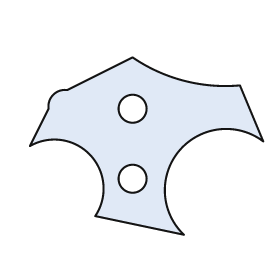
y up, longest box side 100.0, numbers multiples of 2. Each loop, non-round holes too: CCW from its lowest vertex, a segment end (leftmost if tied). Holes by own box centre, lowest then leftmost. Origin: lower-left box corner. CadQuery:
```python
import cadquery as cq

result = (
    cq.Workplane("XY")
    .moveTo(66.0, 0.0)
    .threePointArc((64.0, 36.0), (100.0, 40.0))
    .lineTo(90.0, 64.0)
    .threePointArc((66.0, 66.0), (44.0, 76.0))
    .lineTo(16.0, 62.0)
    .threePointArc((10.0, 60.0), (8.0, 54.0))
    .lineTo(0.0, 38.0)
    .threePointArc((26.0, 34.0), (28.0, 8.0))
    .close()
    .moveTo(44.0, 24.0)
    .circle(6.0)
    .moveTo(44.0, 54.0)
    .circle(6.0)
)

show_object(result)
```